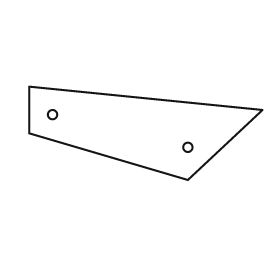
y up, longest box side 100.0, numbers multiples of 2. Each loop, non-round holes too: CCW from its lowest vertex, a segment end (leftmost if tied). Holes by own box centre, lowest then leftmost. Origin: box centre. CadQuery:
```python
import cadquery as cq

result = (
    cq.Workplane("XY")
    .moveTo(18.0, -20.0)
    .lineTo(50.0, 10.0)
    .lineTo(-50.0, 20.0)
    .lineTo(-50.0, 0.0)
    .close()
    .moveTo(18.0, -6.0)
    .circle(2.0)
    .moveTo(-40.0, 8.0)
    .circle(2.0)
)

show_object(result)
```